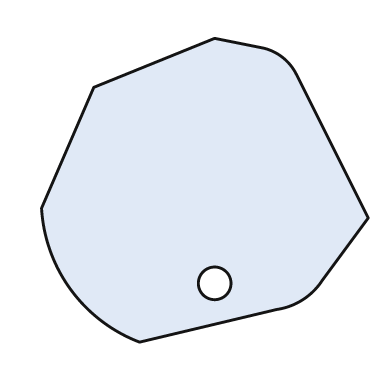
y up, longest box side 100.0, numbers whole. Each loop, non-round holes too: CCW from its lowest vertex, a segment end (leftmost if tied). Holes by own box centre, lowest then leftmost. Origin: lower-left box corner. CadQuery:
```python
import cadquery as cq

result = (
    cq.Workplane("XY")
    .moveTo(30.0, 0.0)
    .lineTo(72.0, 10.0)
    .threePointArc((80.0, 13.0), (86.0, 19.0))
    .lineTo(100.0, 38.0)
    .lineTo(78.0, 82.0)
    .threePointArc((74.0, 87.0), (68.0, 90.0))
    .lineTo(53.0, 93.0)
    .lineTo(16.0, 78.0)
    .lineTo(0.0, 41.0)
    .threePointArc((9.0, 16.0), (30.0, 0.0))
    .close()
    .moveTo(53.0, 18.0)
    .circle(5.0)
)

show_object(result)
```